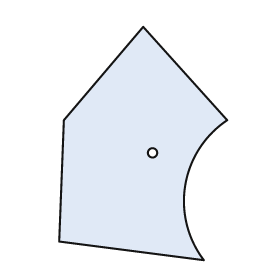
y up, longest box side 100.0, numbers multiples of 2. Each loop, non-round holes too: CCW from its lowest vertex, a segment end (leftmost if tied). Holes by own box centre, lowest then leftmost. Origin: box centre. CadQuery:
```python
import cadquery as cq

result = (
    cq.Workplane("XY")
    .moveTo(26.0, -50.0)
    .threePointArc((18.0, -18.0), (36.0, 10.0))
    .lineTo(0.0, 50.0)
    .lineTo(-34.0, 10.0)
    .lineTo(-36.0, -42.0)
    .close()
    .moveTo(4.0, -4.0)
    .circle(2.0)
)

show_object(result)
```